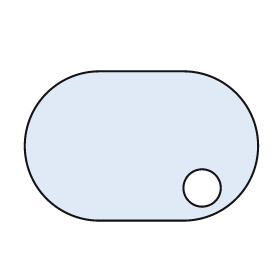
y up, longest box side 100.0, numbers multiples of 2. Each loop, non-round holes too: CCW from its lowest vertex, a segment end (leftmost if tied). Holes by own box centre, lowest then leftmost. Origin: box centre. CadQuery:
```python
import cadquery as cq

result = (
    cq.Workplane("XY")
    .moveTo(-18.0, -32.0)
    .lineTo(18.0, -32.0)
    .threePointArc((50.0, 0.0), (18.0, 32.0))
    .lineTo(-18.0, 32.0)
    .threePointArc((-50.0, 0.0), (-18.0, -32.0))
    .close()
    .moveTo(26.0, -18.0)
    .circle(8.0)
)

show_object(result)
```